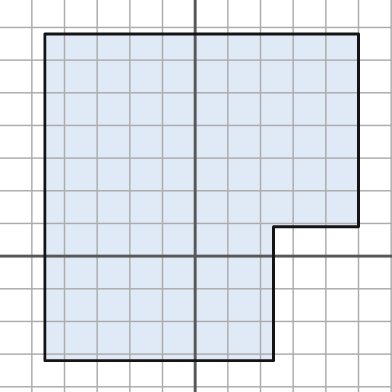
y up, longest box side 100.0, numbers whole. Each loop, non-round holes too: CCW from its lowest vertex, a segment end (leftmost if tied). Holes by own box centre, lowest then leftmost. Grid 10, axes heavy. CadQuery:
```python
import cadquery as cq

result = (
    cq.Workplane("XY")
    .moveTo(-46.0, -32.0)
    .lineTo(24.0, -32.0)
    .lineTo(24.0, 9.0)
    .lineTo(50.0, 9.0)
    .lineTo(50.0, 68.0)
    .lineTo(-46.0, 68.0)
    .close()
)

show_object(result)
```